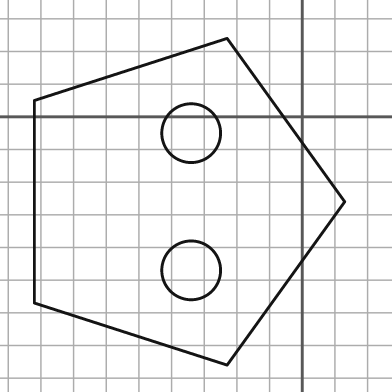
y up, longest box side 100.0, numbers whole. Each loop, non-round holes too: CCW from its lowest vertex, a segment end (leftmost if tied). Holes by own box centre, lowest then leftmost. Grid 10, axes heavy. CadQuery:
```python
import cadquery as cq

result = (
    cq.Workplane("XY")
    .moveTo(-23.0, -76.0)
    .lineTo(13.0, -26.0)
    .lineTo(-23.0, 24.0)
    .lineTo(-82.0, 5.0)
    .lineTo(-82.0, -57.0)
    .close()
    .moveTo(-34.0, -47.0)
    .circle(9.0)
    .moveTo(-34.0, -5.0)
    .circle(9.0)
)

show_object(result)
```